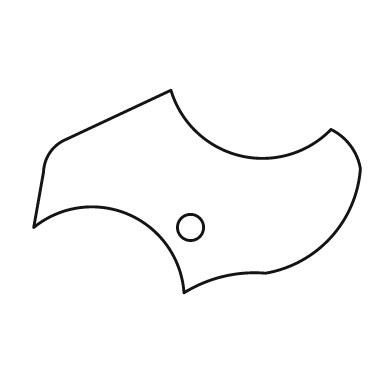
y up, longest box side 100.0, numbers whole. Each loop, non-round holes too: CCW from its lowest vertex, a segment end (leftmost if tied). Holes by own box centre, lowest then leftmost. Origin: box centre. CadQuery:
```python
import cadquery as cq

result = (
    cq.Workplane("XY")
    .moveTo(-4.0, -31.0)
    .threePointArc((8.0, -26.0), (21.0, -25.0))
    .threePointArc((41.0, -14.0), (50.0, 7.0))
    .threePointArc((47.0, 14.0), (41.0, 19.0))
    .threePointArc((13.0, 11.0), (-8.0, 31.0))
    .lineTo(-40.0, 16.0)
    .threePointArc((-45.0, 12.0), (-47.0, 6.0))
    .lineTo(-50.0, -11.0)
    .threePointArc((-21.0, -7.0), (-4.0, -31.0))
    .close()
    .moveTo(-2.0, -11.0)
    .circle(4.0)
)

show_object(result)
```